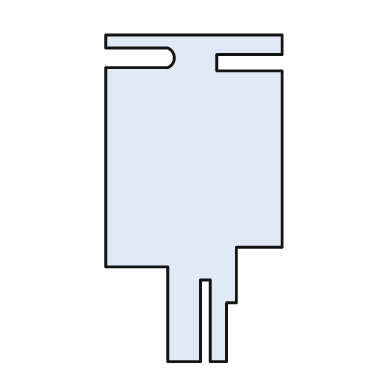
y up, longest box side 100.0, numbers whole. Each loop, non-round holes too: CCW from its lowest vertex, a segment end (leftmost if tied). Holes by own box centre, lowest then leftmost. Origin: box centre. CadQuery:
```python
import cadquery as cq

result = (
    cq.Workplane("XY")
    .moveTo(-8.0, -50.0)
    .lineTo(2.0, -50.0)
    .lineTo(2.0, -25.0)
    .lineTo(5.0, -25.0)
    .lineTo(5.0, -50.0)
    .lineTo(10.0, -50.0)
    .lineTo(10.0, -32.0)
    .lineTo(13.0, -32.0)
    .lineTo(13.0, -15.0)
    .lineTo(27.0, -15.0)
    .lineTo(27.0, 39.0)
    .lineTo(7.0, 39.0)
    .lineTo(7.0, 44.0)
    .lineTo(27.0, 44.0)
    .lineTo(27.0, 50.0)
    .lineTo(-27.0, 50.0)
    .lineTo(-27.0, 46.0)
    .lineTo(-8.0, 46.0)
    .threePointArc((-6.0, 43.0), (-8.0, 40.0))
    .lineTo(-27.0, 40.0)
    .lineTo(-27.0, -21.0)
    .lineTo(-8.0, -21.0)
    .close()
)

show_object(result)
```